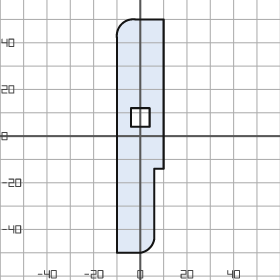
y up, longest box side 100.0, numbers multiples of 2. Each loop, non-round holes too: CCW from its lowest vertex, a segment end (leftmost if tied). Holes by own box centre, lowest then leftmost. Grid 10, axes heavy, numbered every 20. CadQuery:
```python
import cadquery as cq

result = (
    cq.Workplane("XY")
    .moveTo(-10.0, -50.0)
    .lineTo(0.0, -50.0)
    .threePointArc((4.0, -48.0), (6.0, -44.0))
    .lineTo(6.0, -14.0)
    .lineTo(10.0, -14.0)
    .lineTo(10.0, 50.0)
    .lineTo(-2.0, 50.0)
    .threePointArc((-8.0, 48.0), (-10.0, 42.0))
    .close()
    .moveTo(-4.0, 4.0)
    .lineTo(4.0, 4.0)
    .lineTo(4.0, 12.0)
    .lineTo(-4.0, 12.0)
    .close()
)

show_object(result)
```